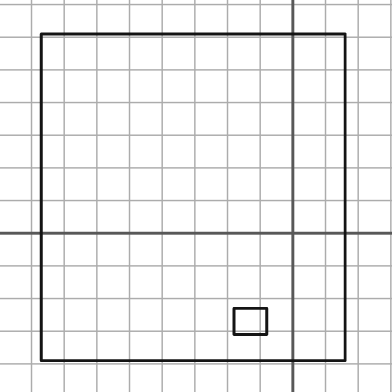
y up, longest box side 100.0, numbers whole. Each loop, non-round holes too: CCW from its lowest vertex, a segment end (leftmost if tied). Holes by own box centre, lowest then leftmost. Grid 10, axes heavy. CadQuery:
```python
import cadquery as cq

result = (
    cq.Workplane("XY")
    .moveTo(-77.0, -39.0)
    .lineTo(16.0, -39.0)
    .lineTo(16.0, 61.0)
    .lineTo(-77.0, 61.0)
    .close()
    .moveTo(-18.0, -31.0)
    .lineTo(-8.0, -31.0)
    .lineTo(-8.0, -23.0)
    .lineTo(-18.0, -23.0)
    .close()
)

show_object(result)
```